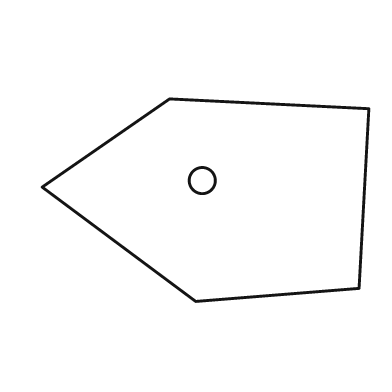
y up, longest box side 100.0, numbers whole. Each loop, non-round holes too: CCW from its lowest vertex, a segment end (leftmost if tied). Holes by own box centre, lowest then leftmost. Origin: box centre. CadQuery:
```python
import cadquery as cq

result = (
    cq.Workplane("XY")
    .moveTo(-3.0, -31.0)
    .lineTo(47.0, -27.0)
    .lineTo(50.0, 28.0)
    .lineTo(-11.0, 31.0)
    .lineTo(-50.0, 4.0)
    .close()
    .moveTo(-1.0, 6.0)
    .circle(4.0)
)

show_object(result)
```